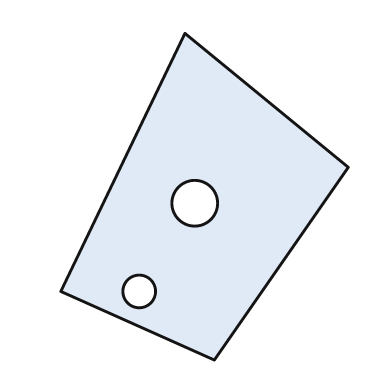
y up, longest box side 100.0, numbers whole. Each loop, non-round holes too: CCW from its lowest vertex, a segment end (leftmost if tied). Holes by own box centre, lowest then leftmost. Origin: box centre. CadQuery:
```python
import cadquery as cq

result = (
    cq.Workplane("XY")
    .moveTo(3.0, -50.0)
    .lineTo(44.0, 9.0)
    .lineTo(-6.0, 50.0)
    .lineTo(-44.0, -29.0)
    .close()
    .moveTo(-20.0, -29.0)
    .circle(5.0)
    .moveTo(-3.0, -2.0)
    .circle(7.0)
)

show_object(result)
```